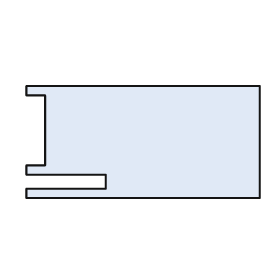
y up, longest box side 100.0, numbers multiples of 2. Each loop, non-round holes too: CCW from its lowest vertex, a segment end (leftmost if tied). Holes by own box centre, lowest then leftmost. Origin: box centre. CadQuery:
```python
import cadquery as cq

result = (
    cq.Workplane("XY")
    .moveTo(-50.0, -24.0)
    .lineTo(50.0, -24.0)
    .lineTo(50.0, 24.0)
    .lineTo(-50.0, 24.0)
    .lineTo(-50.0, 20.0)
    .lineTo(-42.0, 20.0)
    .lineTo(-42.0, -10.0)
    .lineTo(-50.0, -10.0)
    .lineTo(-50.0, -14.0)
    .lineTo(-16.0, -14.0)
    .lineTo(-16.0, -20.0)
    .lineTo(-50.0, -20.0)
    .close()
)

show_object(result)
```